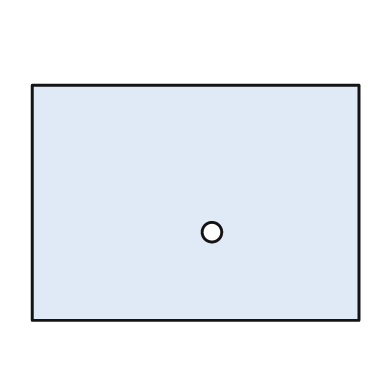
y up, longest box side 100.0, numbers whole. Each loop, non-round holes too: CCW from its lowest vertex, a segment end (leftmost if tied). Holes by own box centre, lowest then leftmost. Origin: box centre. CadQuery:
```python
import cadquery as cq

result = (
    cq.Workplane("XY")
    .moveTo(-50.0, -36.0)
    .lineTo(50.0, -36.0)
    .lineTo(50.0, 36.0)
    .lineTo(-50.0, 36.0)
    .close()
    .moveTo(5.0, -9.0)
    .circle(3.0)
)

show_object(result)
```